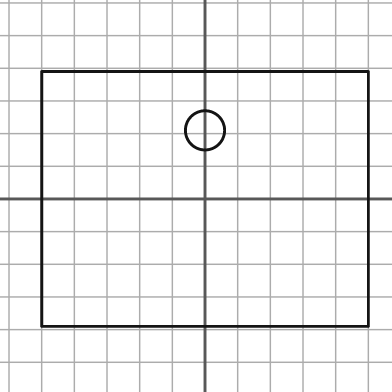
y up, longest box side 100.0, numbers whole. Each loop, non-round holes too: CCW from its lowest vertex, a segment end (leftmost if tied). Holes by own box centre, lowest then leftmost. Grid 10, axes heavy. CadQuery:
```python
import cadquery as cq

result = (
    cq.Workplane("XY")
    .moveTo(-50.0, -39.0)
    .lineTo(50.0, -39.0)
    .lineTo(50.0, 39.0)
    .lineTo(-50.0, 39.0)
    .close()
    .moveTo(0.0, 21.0)
    .circle(6.0)
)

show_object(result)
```